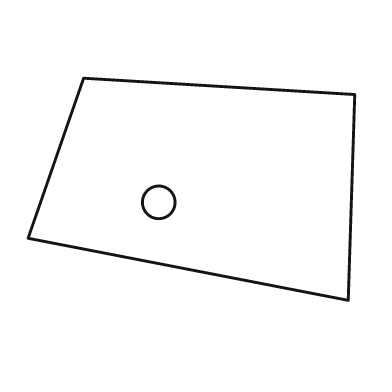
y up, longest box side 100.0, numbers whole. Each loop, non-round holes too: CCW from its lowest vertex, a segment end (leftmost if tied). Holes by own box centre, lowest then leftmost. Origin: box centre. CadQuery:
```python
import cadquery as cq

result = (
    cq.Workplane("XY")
    .moveTo(48.0, -34.0)
    .lineTo(50.0, 29.0)
    .lineTo(-33.0, 34.0)
    .lineTo(-50.0, -15.0)
    .close()
    .moveTo(-10.0, -4.0)
    .circle(5.0)
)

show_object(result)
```